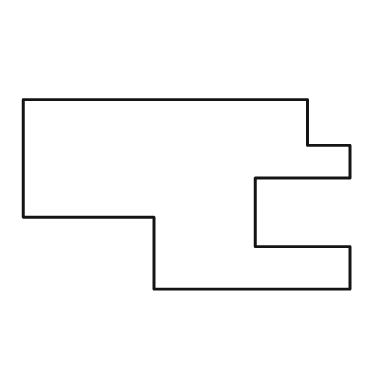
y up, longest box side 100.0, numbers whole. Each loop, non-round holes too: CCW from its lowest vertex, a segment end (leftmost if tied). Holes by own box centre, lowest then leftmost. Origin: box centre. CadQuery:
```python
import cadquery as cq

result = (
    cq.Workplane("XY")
    .moveTo(-10.0, -29.0)
    .lineTo(50.0, -29.0)
    .lineTo(50.0, -16.0)
    .lineTo(21.0, -16.0)
    .lineTo(21.0, 5.0)
    .lineTo(50.0, 5.0)
    .lineTo(50.0, 15.0)
    .lineTo(37.0, 15.0)
    .lineTo(37.0, 29.0)
    .lineTo(-50.0, 29.0)
    .lineTo(-50.0, -7.0)
    .lineTo(-10.0, -7.0)
    .close()
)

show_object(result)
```